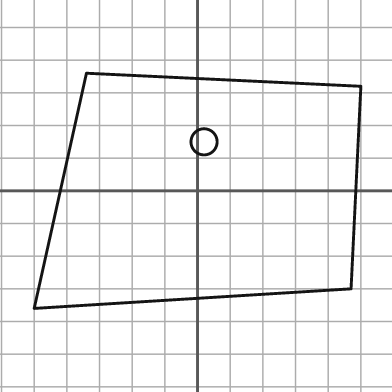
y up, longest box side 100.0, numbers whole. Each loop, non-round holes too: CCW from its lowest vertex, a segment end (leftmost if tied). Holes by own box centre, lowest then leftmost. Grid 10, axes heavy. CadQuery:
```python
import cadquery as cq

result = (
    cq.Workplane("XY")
    .moveTo(-50.0, -36.0)
    .lineTo(47.0, -30.0)
    .lineTo(50.0, 32.0)
    .lineTo(-34.0, 36.0)
    .close()
    .moveTo(2.0, 15.0)
    .circle(4.0)
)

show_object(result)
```